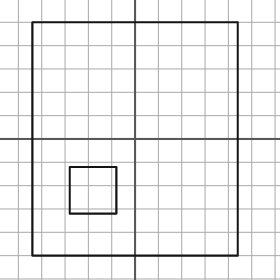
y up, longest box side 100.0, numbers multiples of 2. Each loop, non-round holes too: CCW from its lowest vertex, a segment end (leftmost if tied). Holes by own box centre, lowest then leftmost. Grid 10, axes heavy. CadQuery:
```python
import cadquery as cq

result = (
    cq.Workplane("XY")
    .moveTo(-44.0, -50.0)
    .lineTo(44.0, -50.0)
    .lineTo(44.0, 50.0)
    .lineTo(-44.0, 50.0)
    .close()
    .moveTo(-28.0, -32.0)
    .lineTo(-8.0, -32.0)
    .lineTo(-8.0, -12.0)
    .lineTo(-28.0, -12.0)
    .close()
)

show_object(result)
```